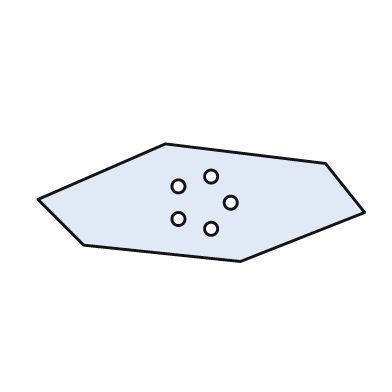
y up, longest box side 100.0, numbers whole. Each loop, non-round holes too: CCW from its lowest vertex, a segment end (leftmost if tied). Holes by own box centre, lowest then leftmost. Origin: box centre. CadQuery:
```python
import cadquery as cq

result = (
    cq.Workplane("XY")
    .moveTo(12.0, -18.0)
    .lineTo(50.0, -3.0)
    .lineTo(38.0, 12.0)
    .lineTo(-11.0, 18.0)
    .lineTo(-50.0, 1.0)
    .lineTo(-36.0, -13.0)
    .close()
    .moveTo(3.0, -8.0)
    .circle(2.0)
    .moveTo(-7.0, -5.0)
    .circle(2.0)
    .moveTo(9.0, 0.0)
    .circle(2.0)
    .moveTo(-7.0, 5.0)
    .circle(2.0)
    .moveTo(3.0, 8.0)
    .circle(2.0)
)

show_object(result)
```